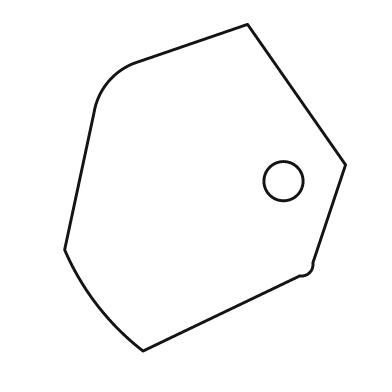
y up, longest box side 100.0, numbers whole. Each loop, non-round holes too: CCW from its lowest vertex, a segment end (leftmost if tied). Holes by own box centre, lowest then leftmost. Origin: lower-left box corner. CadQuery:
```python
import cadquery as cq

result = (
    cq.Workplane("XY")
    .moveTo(24.0, 0.0)
    .lineTo(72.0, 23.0)
    .threePointArc((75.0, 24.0), (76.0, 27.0))
    .lineTo(86.0, 57.0)
    .lineTo(56.0, 100.0)
    .lineTo(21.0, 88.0)
    .threePointArc((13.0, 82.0), (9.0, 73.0))
    .lineTo(0.0, 31.0)
    .threePointArc((10.0, 14.0), (24.0, 0.0))
    .close()
    .moveTo(67.0, 52.0)
    .circle(6.0)
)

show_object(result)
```